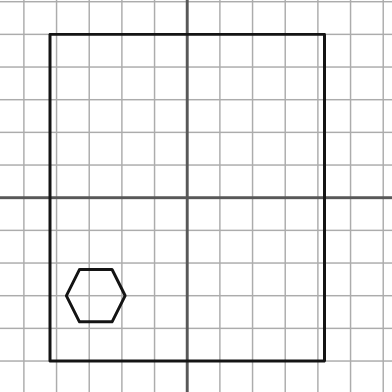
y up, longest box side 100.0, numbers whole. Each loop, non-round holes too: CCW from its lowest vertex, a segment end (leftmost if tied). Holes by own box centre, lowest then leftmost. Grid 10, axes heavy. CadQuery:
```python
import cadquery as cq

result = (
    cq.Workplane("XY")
    .moveTo(-42.0, -50.0)
    .lineTo(42.0, -50.0)
    .lineTo(42.0, 50.0)
    .lineTo(-42.0, 50.0)
    .close()
    .moveTo(-33.0, -38.0)
    .lineTo(-23.0, -38.0)
    .lineTo(-19.0, -30.0)
    .lineTo(-23.0, -22.0)
    .lineTo(-33.0, -22.0)
    .lineTo(-37.0, -30.0)
    .close()
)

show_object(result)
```